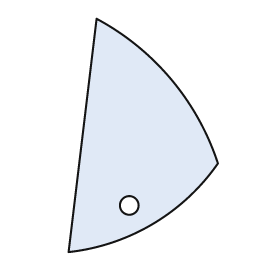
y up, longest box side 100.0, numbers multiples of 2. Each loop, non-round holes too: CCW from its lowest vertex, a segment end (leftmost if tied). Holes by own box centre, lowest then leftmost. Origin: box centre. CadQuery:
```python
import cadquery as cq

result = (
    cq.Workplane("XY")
    .moveTo(-32.0, -50.0)
    .threePointArc((4.0, -38.0), (32.0, -12.0))
    .threePointArc((12.0, 24.0), (-20.0, 50.0))
    .close()
    .moveTo(-6.0, -30.0)
    .circle(4.0)
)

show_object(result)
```